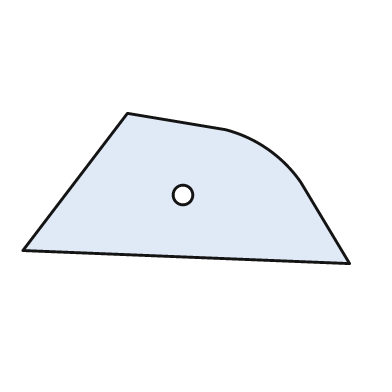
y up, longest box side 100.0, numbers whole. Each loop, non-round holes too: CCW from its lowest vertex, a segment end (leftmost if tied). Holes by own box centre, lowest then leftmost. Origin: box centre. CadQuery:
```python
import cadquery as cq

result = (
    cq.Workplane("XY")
    .moveTo(50.0, -23.0)
    .lineTo(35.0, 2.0)
    .threePointArc((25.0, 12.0), (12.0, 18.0))
    .lineTo(-18.0, 23.0)
    .lineTo(-50.0, -19.0)
    .close()
    .moveTo(-1.0, -2.0)
    .circle(3.0)
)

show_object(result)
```